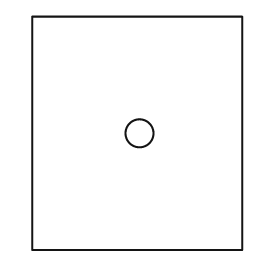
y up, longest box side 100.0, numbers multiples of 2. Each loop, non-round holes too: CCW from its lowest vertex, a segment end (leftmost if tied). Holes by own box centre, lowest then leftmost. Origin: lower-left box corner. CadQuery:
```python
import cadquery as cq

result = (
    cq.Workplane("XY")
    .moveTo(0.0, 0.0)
    .lineTo(90.0, 0.0)
    .lineTo(90.0, 100.0)
    .lineTo(0.0, 100.0)
    .close()
    .moveTo(46.0, 50.0)
    .circle(6.0)
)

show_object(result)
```